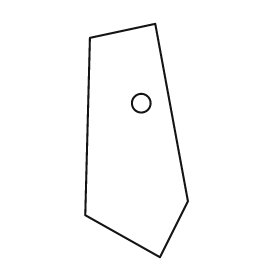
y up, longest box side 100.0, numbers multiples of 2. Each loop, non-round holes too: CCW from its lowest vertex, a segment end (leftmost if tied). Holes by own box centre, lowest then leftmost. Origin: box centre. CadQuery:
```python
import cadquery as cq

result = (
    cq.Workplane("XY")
    .moveTo(10.0, -50.0)
    .lineTo(22.0, -26.0)
    .lineTo(8.0, 50.0)
    .lineTo(-20.0, 44.0)
    .lineTo(-22.0, -32.0)
    .close()
    .moveTo(2.0, 16.0)
    .circle(4.0)
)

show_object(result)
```